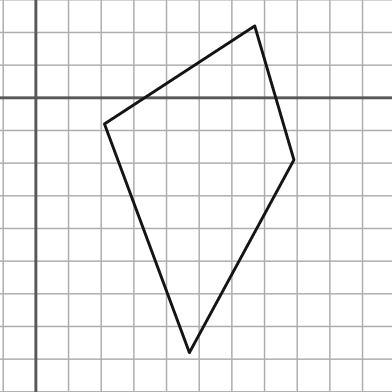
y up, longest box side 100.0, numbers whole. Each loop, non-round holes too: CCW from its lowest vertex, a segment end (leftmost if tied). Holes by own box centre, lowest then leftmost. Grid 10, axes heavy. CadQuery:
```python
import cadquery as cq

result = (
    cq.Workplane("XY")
    .moveTo(47.0, -78.0)
    .lineTo(79.0, -19.0)
    .lineTo(67.0, 22.0)
    .lineTo(21.0, -8.0)
    .close()
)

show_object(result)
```